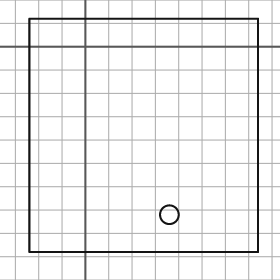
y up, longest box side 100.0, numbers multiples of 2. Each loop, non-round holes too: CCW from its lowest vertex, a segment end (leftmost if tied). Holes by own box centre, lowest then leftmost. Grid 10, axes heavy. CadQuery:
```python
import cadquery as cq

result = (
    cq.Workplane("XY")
    .moveTo(-24.0, -88.0)
    .lineTo(74.0, -88.0)
    .lineTo(74.0, 12.0)
    .lineTo(-24.0, 12.0)
    .close()
    .moveTo(36.0, -72.0)
    .circle(4.0)
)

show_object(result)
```